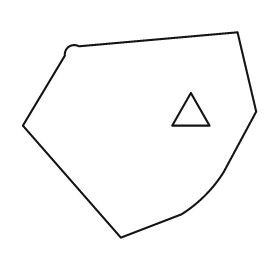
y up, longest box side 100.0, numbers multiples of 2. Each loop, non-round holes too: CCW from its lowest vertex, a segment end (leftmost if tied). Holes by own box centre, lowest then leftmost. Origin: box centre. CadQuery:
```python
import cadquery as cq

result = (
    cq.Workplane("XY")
    .moveTo(-8.0, -44.0)
    .lineTo(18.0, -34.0)
    .threePointArc((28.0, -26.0), (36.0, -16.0))
    .lineTo(50.0, 10.0)
    .lineTo(42.0, 44.0)
    .lineTo(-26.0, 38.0)
    .threePointArc((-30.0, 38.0), (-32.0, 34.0))
    .lineTo(-50.0, 4.0)
    .close()
    .moveTo(14.0, 4.0)
    .lineTo(30.0, 4.0)
    .lineTo(22.0, 18.0)
    .close()
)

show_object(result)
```